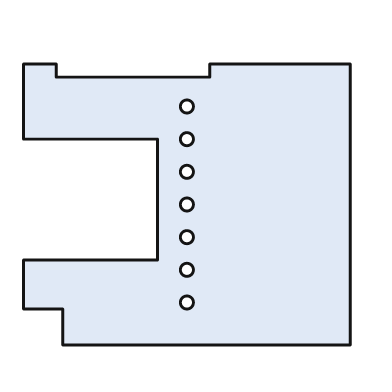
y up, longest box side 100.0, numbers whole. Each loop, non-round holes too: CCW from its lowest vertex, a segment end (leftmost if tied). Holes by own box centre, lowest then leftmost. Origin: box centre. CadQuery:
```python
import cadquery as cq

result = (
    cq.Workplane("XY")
    .moveTo(-38.0, -43.0)
    .lineTo(50.0, -43.0)
    .lineTo(50.0, 43.0)
    .lineTo(7.0, 43.0)
    .lineTo(7.0, 39.0)
    .lineTo(-40.0, 39.0)
    .lineTo(-40.0, 43.0)
    .lineTo(-50.0, 43.0)
    .lineTo(-50.0, 20.0)
    .lineTo(-9.0, 20.0)
    .lineTo(-9.0, -17.0)
    .lineTo(-50.0, -17.0)
    .lineTo(-50.0, -32.0)
    .lineTo(-38.0, -32.0)
    .close()
    .moveTo(0.0, -30.0)
    .circle(2.0)
    .moveTo(0.0, -20.0)
    .circle(2.0)
    .moveTo(0.0, -10.0)
    .circle(2.0)
    .moveTo(0.0, 0.0)
    .circle(2.0)
    .moveTo(0.0, 10.0)
    .circle(2.0)
    .moveTo(0.0, 20.0)
    .circle(2.0)
    .moveTo(0.0, 30.0)
    .circle(2.0)
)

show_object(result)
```